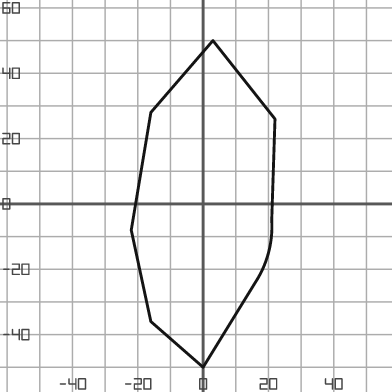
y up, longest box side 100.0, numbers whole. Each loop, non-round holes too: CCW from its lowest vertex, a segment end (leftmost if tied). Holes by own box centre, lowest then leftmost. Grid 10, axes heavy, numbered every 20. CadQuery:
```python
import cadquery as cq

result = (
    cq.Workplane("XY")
    .moveTo(0.0, -50.0)
    .lineTo(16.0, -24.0)
    .threePointArc((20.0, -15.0), (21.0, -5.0))
    .lineTo(22.0, 26.0)
    .lineTo(3.0, 50.0)
    .lineTo(-16.0, 28.0)
    .lineTo(-22.0, -8.0)
    .lineTo(-16.0, -36.0)
    .close()
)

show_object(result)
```